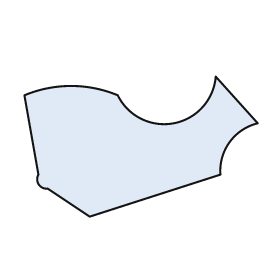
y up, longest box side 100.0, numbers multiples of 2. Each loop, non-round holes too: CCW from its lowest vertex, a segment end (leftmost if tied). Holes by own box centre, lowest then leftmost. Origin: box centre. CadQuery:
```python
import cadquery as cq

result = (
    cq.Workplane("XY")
    .moveTo(-22.0, -30.0)
    .lineTo(34.0, -12.0)
    .threePointArc((38.0, 2.0), (50.0, 10.0))
    .lineTo(32.0, 30.0)
    .threePointArc((14.0, 10.0), (-10.0, 22.0))
    .threePointArc((-30.0, 26.0), (-50.0, 22.0))
    .lineTo(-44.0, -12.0)
    .threePointArc((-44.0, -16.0), (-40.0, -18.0))
    .close()
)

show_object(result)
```